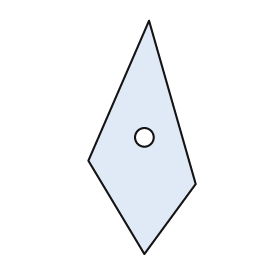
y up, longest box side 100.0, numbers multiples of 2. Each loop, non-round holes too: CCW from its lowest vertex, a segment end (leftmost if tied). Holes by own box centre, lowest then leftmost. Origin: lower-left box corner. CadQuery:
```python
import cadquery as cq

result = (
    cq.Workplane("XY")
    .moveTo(24.0, 0.0)
    .lineTo(46.0, 30.0)
    .lineTo(26.0, 100.0)
    .lineTo(0.0, 40.0)
    .close()
    .moveTo(24.0, 50.0)
    .circle(4.0)
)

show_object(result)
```